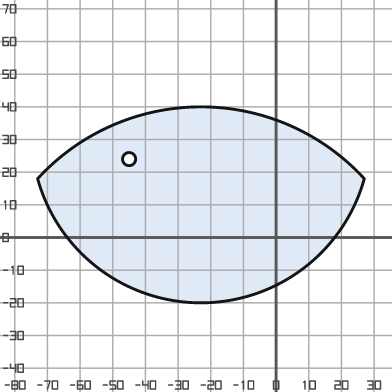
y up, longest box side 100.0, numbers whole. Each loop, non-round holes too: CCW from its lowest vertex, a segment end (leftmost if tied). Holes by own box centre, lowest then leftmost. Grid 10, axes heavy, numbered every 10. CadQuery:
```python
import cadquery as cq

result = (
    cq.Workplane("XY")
    .moveTo(-73.0, 18.0)
    .threePointArc((-23.0, -20.0), (27.0, 18.0))
    .threePointArc((-23.0, 40.0), (-73.0, 18.0))
    .close()
    .moveTo(-45.0, 24.0)
    .circle(2.0)
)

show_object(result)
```